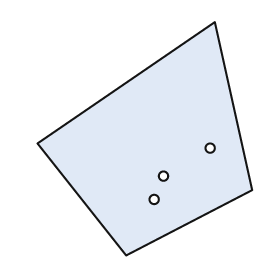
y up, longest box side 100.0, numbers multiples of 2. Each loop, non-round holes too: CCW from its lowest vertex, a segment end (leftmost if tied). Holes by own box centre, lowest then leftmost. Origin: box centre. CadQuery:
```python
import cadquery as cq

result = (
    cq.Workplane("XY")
    .moveTo(-8.0, -50.0)
    .lineTo(46.0, -22.0)
    .lineTo(30.0, 50.0)
    .lineTo(-46.0, -2.0)
    .close()
    .moveTo(4.0, -26.0)
    .circle(2.0)
    .moveTo(8.0, -16.0)
    .circle(2.0)
    .moveTo(28.0, -4.0)
    .circle(2.0)
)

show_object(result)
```